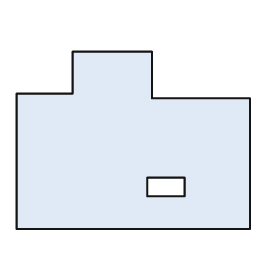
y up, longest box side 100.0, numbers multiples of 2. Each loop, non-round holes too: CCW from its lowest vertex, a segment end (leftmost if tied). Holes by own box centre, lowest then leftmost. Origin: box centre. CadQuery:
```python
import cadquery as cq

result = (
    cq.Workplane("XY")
    .moveTo(-50.0, -38.0)
    .lineTo(50.0, -38.0)
    .lineTo(50.0, 18.0)
    .lineTo(8.0, 18.0)
    .lineTo(8.0, 38.0)
    .lineTo(-26.0, 38.0)
    .lineTo(-26.0, 20.0)
    .lineTo(-50.0, 20.0)
    .close()
    .moveTo(6.0, -24.0)
    .lineTo(22.0, -24.0)
    .lineTo(22.0, -16.0)
    .lineTo(6.0, -16.0)
    .close()
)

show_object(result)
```